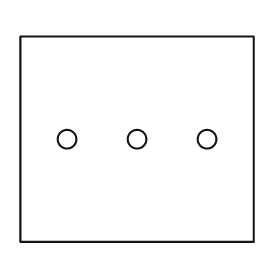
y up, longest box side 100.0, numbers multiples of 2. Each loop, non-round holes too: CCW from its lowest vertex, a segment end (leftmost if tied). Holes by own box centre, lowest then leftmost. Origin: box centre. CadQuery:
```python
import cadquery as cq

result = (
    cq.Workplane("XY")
    .moveTo(-50.0, -44.0)
    .lineTo(50.0, -44.0)
    .lineTo(50.0, 44.0)
    .lineTo(-50.0, 44.0)
    .close()
    .moveTo(-30.0, 0.0)
    .circle(4.0)
    .moveTo(0.0, 0.0)
    .circle(4.0)
    .moveTo(30.0, 0.0)
    .circle(4.0)
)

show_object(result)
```